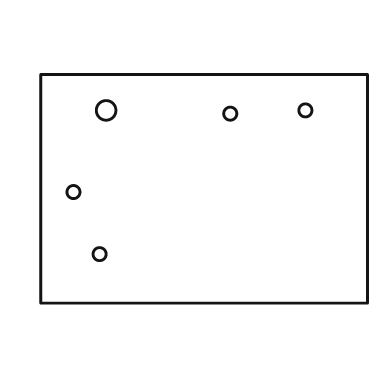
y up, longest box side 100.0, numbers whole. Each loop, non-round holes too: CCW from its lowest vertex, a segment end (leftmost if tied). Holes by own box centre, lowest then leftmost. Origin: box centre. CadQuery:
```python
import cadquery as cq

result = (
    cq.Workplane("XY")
    .moveTo(-50.0, -35.0)
    .lineTo(50.0, -35.0)
    .lineTo(50.0, 35.0)
    .lineTo(-50.0, 35.0)
    .close()
    .moveTo(-32.0, -20.0)
    .circle(2.0)
    .moveTo(-40.0, -1.0)
    .circle(2.0)
    .moveTo(8.0, 23.0)
    .circle(2.0)
    .moveTo(-30.0, 24.0)
    .circle(3.0)
    .moveTo(31.0, 24.0)
    .circle(2.0)
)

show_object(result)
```